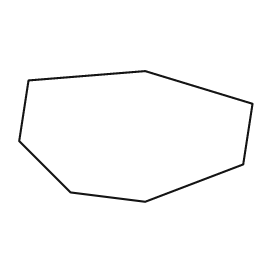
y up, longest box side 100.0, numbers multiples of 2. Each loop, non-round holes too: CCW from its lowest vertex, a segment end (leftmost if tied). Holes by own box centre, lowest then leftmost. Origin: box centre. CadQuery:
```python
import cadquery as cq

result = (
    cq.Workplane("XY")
    .moveTo(4.0, -28.0)
    .lineTo(46.0, -12.0)
    .lineTo(50.0, 14.0)
    .lineTo(4.0, 28.0)
    .lineTo(-46.0, 24.0)
    .lineTo(-50.0, -2.0)
    .lineTo(-28.0, -24.0)
    .close()
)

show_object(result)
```